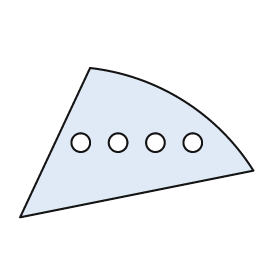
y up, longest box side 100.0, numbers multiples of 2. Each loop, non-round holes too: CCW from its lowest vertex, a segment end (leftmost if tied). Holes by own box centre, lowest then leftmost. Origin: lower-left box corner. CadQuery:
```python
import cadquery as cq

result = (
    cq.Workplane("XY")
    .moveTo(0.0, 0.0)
    .lineTo(100.0, 20.0)
    .threePointArc((70.0, 50.0), (30.0, 64.0))
    .close()
    .moveTo(26.0, 32.0)
    .circle(4.0)
    .moveTo(42.0, 32.0)
    .circle(4.0)
    .moveTo(58.0, 32.0)
    .circle(4.0)
    .moveTo(74.0, 32.0)
    .circle(4.0)
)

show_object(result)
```